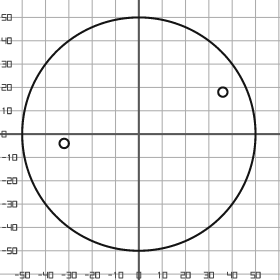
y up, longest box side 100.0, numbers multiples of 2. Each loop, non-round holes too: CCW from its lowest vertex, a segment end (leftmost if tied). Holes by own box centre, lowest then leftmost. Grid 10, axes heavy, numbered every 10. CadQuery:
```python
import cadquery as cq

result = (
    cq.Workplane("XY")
    .moveTo(0.0, 0.0)
    .circle(50.0)
    .moveTo(-32.0, -4.0)
    .circle(2.0)
    .moveTo(36.0, 18.0)
    .circle(2.0)
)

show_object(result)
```